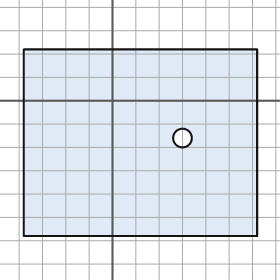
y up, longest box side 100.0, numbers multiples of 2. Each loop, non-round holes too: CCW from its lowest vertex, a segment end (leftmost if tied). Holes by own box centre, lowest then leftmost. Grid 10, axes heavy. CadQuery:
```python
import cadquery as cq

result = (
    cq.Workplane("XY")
    .moveTo(-38.0, -58.0)
    .lineTo(62.0, -58.0)
    .lineTo(62.0, 22.0)
    .lineTo(-38.0, 22.0)
    .close()
    .moveTo(30.0, -16.0)
    .circle(4.0)
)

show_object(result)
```